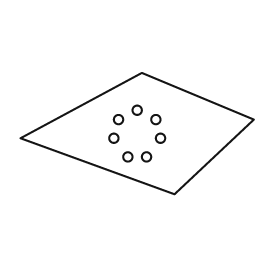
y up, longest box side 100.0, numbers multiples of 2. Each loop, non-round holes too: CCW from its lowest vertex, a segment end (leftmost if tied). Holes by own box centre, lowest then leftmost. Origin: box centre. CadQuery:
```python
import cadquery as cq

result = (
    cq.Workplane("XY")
    .moveTo(16.0, -26.0)
    .lineTo(50.0, 6.0)
    .lineTo(2.0, 26.0)
    .lineTo(-50.0, -2.0)
    .close()
    .moveTo(-4.0, -10.0)
    .circle(2.0)
    .moveTo(4.0, -10.0)
    .circle(2.0)
    .moveTo(-10.0, -2.0)
    .circle(2.0)
    .moveTo(10.0, -2.0)
    .circle(2.0)
    .moveTo(-8.0, 6.0)
    .circle(2.0)
    .moveTo(8.0, 6.0)
    .circle(2.0)
    .moveTo(0.0, 10.0)
    .circle(2.0)
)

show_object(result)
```